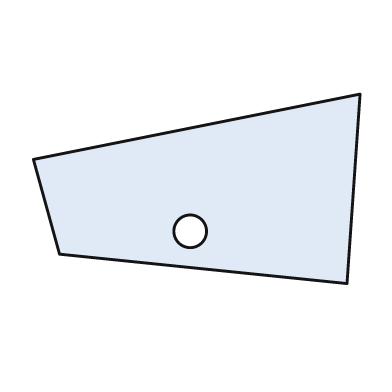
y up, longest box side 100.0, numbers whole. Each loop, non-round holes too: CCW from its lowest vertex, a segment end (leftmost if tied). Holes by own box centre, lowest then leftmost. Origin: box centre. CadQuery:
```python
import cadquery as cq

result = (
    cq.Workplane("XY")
    .moveTo(46.0, -29.0)
    .lineTo(50.0, 29.0)
    .lineTo(-50.0, 9.0)
    .lineTo(-42.0, -20.0)
    .close()
    .moveTo(-2.0, -13.0)
    .circle(5.0)
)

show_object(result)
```